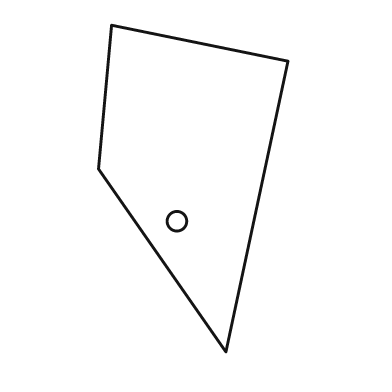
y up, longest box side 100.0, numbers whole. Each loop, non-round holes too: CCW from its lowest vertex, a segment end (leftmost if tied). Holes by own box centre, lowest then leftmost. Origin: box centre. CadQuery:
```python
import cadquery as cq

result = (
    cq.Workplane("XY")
    .moveTo(10.0, -50.0)
    .lineTo(29.0, 39.0)
    .lineTo(-25.0, 50.0)
    .lineTo(-29.0, 6.0)
    .close()
    .moveTo(-5.0, -10.0)
    .circle(3.0)
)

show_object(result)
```